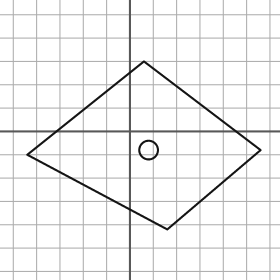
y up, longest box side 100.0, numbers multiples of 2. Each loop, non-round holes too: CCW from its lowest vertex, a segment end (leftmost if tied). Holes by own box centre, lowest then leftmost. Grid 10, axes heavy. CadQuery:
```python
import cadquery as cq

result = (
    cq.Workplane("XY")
    .moveTo(16.0, -42.0)
    .lineTo(56.0, -8.0)
    .lineTo(6.0, 30.0)
    .lineTo(-44.0, -10.0)
    .close()
    .moveTo(8.0, -8.0)
    .circle(4.0)
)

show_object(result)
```